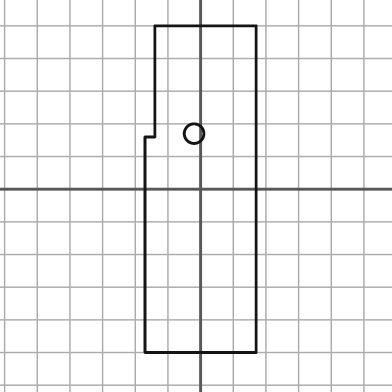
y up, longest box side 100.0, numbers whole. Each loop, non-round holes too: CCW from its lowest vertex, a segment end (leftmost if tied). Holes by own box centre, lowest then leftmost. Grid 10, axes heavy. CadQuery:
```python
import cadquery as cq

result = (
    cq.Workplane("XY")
    .moveTo(-17.0, -50.0)
    .lineTo(17.0, -50.0)
    .lineTo(17.0, 50.0)
    .lineTo(-14.0, 50.0)
    .lineTo(-14.0, 16.0)
    .lineTo(-17.0, 16.0)
    .close()
    .moveTo(-2.0, 17.0)
    .circle(3.0)
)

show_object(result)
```